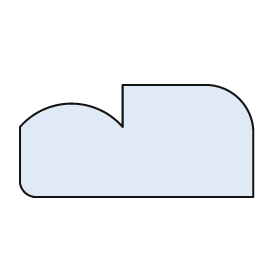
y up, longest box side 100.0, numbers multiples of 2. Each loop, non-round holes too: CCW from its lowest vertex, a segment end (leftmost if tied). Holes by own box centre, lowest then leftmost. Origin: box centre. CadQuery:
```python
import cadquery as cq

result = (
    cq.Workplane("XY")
    .moveTo(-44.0, -24.0)
    .lineTo(50.0, -24.0)
    .lineTo(50.0, 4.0)
    .threePointArc((44.0, 18.0), (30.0, 24.0))
    .lineTo(-6.0, 24.0)
    .lineTo(-6.0, 6.0)
    .threePointArc((-28.0, 16.0), (-50.0, 6.0))
    .lineTo(-50.0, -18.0)
    .threePointArc((-48.0, -22.0), (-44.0, -24.0))
    .close()
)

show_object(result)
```